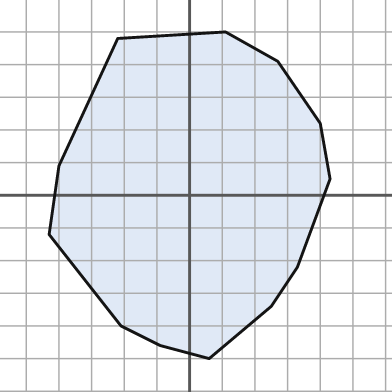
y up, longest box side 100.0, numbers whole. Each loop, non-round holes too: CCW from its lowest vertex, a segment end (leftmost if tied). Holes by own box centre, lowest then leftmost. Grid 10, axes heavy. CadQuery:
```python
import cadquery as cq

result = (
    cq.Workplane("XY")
    .moveTo(6.0, -50.0)
    .lineTo(25.0, -34.0)
    .lineTo(33.0, -22.0)
    .lineTo(43.0, 5.0)
    .lineTo(40.0, 22.0)
    .lineTo(27.0, 41.0)
    .lineTo(11.0, 50.0)
    .lineTo(-22.0, 48.0)
    .lineTo(-40.0, 9.0)
    .lineTo(-43.0, -12.0)
    .lineTo(-21.0, -40.0)
    .lineTo(-9.0, -46.0)
    .close()
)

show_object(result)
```